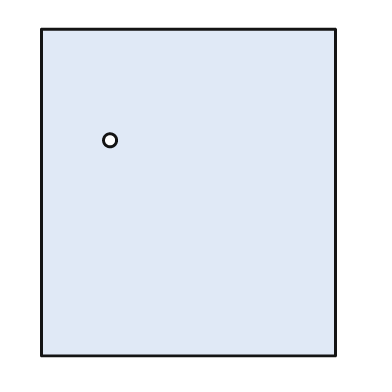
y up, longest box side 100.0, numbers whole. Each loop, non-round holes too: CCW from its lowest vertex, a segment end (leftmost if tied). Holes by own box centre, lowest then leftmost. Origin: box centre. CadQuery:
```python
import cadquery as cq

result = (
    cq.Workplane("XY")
    .moveTo(-45.0, -50.0)
    .lineTo(45.0, -50.0)
    .lineTo(45.0, 50.0)
    .lineTo(-45.0, 50.0)
    .close()
    .moveTo(-24.0, 16.0)
    .circle(2.0)
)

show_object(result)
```